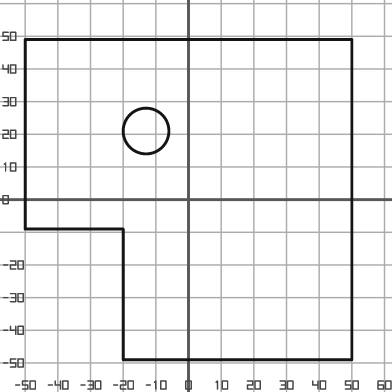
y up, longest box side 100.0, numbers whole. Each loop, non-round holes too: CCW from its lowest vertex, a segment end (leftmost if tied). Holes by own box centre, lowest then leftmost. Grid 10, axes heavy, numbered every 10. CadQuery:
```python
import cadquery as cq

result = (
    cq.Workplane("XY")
    .moveTo(-20.0, -49.0)
    .lineTo(50.0, -49.0)
    .lineTo(50.0, 49.0)
    .lineTo(-50.0, 49.0)
    .lineTo(-50.0, -9.0)
    .lineTo(-20.0, -9.0)
    .close()
    .moveTo(-13.0, 21.0)
    .circle(7.0)
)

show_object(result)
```